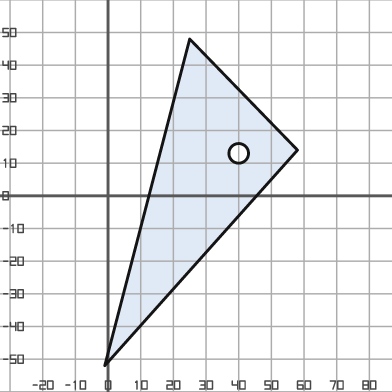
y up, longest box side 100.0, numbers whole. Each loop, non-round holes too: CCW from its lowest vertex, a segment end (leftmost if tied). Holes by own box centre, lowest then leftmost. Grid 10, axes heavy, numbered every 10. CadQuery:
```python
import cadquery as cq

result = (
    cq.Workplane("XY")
    .moveTo(-1.0, -52.0)
    .lineTo(58.0, 14.0)
    .lineTo(25.0, 48.0)
    .close()
    .moveTo(40.0, 13.0)
    .circle(3.0)
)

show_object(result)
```